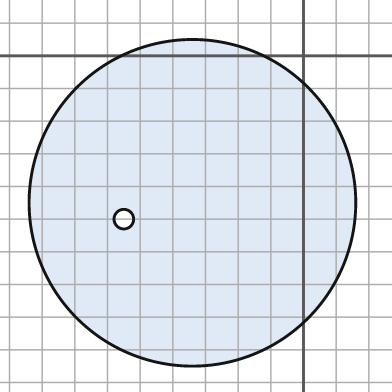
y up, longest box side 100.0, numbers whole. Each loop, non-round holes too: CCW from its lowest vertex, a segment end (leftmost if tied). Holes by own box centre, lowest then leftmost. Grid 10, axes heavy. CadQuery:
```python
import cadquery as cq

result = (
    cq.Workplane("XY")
    .moveTo(-34.0, -45.0)
    .circle(50.0)
    .moveTo(-55.0, -50.0)
    .circle(3.0)
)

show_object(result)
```